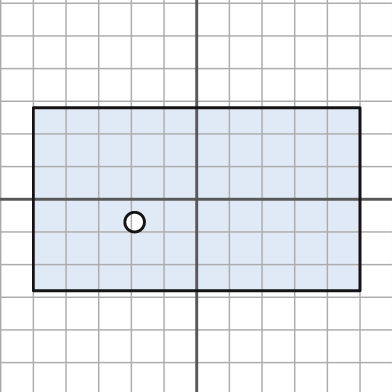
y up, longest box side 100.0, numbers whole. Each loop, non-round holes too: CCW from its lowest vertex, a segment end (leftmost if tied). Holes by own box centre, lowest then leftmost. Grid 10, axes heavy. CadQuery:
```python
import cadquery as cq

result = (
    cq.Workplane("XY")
    .moveTo(-50.0, -28.0)
    .lineTo(50.0, -28.0)
    .lineTo(50.0, 28.0)
    .lineTo(-50.0, 28.0)
    .close()
    .moveTo(-19.0, -7.0)
    .circle(3.0)
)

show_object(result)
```